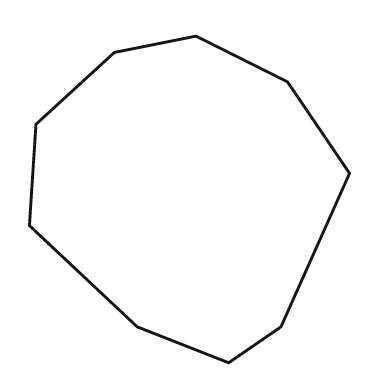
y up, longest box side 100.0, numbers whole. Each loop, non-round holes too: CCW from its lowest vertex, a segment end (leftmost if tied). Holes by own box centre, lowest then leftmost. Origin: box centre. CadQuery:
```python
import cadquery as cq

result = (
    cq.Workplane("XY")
    .moveTo(12.0, -50.0)
    .lineTo(28.0, -39.0)
    .lineTo(49.0, 8.0)
    .lineTo(30.0, 36.0)
    .lineTo(2.0, 50.0)
    .lineTo(-23.0, 45.0)
    .lineTo(-47.0, 23.0)
    .lineTo(-49.0, -8.0)
    .lineTo(-16.0, -39.0)
    .close()
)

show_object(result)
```